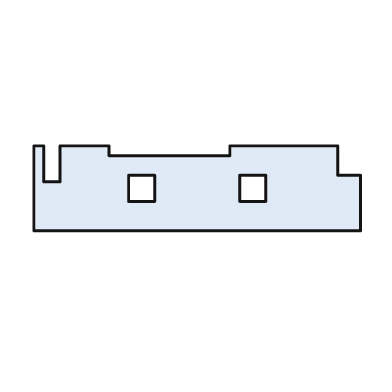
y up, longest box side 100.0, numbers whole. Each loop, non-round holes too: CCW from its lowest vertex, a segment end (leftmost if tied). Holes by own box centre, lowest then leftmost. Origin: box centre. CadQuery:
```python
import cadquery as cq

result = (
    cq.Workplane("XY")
    .moveTo(-50.0, -13.0)
    .lineTo(50.0, -13.0)
    .lineTo(50.0, 4.0)
    .lineTo(43.0, 4.0)
    .lineTo(43.0, 13.0)
    .lineTo(10.0, 13.0)
    .lineTo(10.0, 10.0)
    .lineTo(-27.0, 10.0)
    .lineTo(-27.0, 13.0)
    .lineTo(-42.0, 13.0)
    .lineTo(-42.0, 2.0)
    .lineTo(-47.0, 2.0)
    .lineTo(-47.0, 13.0)
    .lineTo(-50.0, 13.0)
    .close()
    .moveTo(-21.0, -4.0)
    .lineTo(-13.0, -4.0)
    .lineTo(-13.0, 4.0)
    .lineTo(-21.0, 4.0)
    .close()
    .moveTo(13.0, -4.0)
    .lineTo(21.0, -4.0)
    .lineTo(21.0, 4.0)
    .lineTo(13.0, 4.0)
    .close()
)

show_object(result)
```